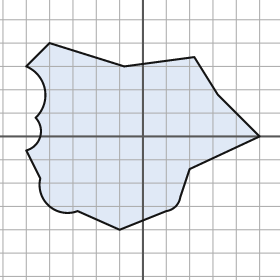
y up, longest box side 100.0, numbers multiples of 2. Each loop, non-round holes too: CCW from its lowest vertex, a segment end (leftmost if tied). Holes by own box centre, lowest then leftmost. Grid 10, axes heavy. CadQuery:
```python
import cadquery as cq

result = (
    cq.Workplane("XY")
    .moveTo(-10.0, -40.0)
    .lineTo(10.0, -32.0)
    .threePointArc((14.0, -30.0), (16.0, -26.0))
    .lineTo(20.0, -14.0)
    .lineTo(50.0, 0.0)
    .lineTo(32.0, 18.0)
    .lineTo(22.0, 34.0)
    .lineTo(-8.0, 30.0)
    .lineTo(-40.0, 40.0)
    .lineTo(-50.0, 30.0)
    .threePointArc((-42.0, 20.0), (-46.0, 8.0))
    .threePointArc((-44.0, 0.0), (-50.0, -6.0))
    .lineTo(-44.0, -18.0)
    .threePointArc((-40.0, -30.0), (-28.0, -32.0))
    .close()
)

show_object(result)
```